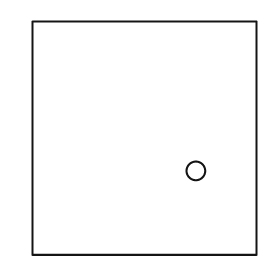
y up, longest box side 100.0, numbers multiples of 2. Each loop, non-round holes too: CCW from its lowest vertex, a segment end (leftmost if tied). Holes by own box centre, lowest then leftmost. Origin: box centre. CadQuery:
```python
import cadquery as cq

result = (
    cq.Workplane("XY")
    .moveTo(-48.0, -50.0)
    .lineTo(48.0, -50.0)
    .lineTo(48.0, 50.0)
    .lineTo(-48.0, 50.0)
    .close()
    .moveTo(22.0, -14.0)
    .circle(4.0)
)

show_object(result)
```